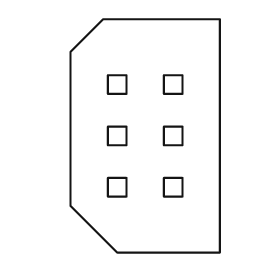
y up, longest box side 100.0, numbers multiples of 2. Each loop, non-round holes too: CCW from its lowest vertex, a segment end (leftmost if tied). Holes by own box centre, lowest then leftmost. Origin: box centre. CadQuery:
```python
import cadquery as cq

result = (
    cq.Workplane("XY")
    .moveTo(-12.0, -50.0)
    .lineTo(32.0, -50.0)
    .lineTo(32.0, 50.0)
    .lineTo(-18.0, 50.0)
    .lineTo(-32.0, 36.0)
    .lineTo(-32.0, -30.0)
    .close()
    .moveTo(-16.0, -26.0)
    .lineTo(-8.0, -26.0)
    .lineTo(-8.0, -18.0)
    .lineTo(-16.0, -18.0)
    .close()
    .moveTo(8.0, -26.0)
    .lineTo(16.0, -26.0)
    .lineTo(16.0, -18.0)
    .lineTo(8.0, -18.0)
    .close()
    .moveTo(-16.0, -4.0)
    .lineTo(-8.0, -4.0)
    .lineTo(-8.0, 4.0)
    .lineTo(-16.0, 4.0)
    .close()
    .moveTo(8.0, -4.0)
    .lineTo(16.0, -4.0)
    .lineTo(16.0, 4.0)
    .lineTo(8.0, 4.0)
    .close()
    .moveTo(-16.0, 18.0)
    .lineTo(-8.0, 18.0)
    .lineTo(-8.0, 26.0)
    .lineTo(-16.0, 26.0)
    .close()
    .moveTo(8.0, 18.0)
    .lineTo(16.0, 18.0)
    .lineTo(16.0, 26.0)
    .lineTo(8.0, 26.0)
    .close()
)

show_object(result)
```